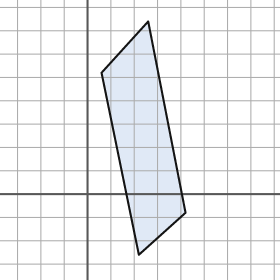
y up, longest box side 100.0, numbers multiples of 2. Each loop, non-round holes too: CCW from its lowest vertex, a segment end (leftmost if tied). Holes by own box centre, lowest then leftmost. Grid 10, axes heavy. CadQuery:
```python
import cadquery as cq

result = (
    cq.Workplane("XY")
    .moveTo(22.0, -26.0)
    .lineTo(42.0, -8.0)
    .lineTo(26.0, 74.0)
    .lineTo(6.0, 52.0)
    .close()
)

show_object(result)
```